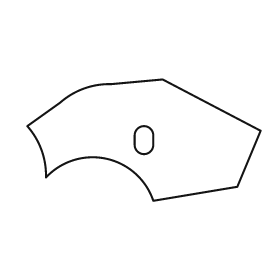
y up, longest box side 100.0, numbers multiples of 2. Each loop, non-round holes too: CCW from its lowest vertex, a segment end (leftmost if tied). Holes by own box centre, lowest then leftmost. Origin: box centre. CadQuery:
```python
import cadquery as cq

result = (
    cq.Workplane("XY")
    .moveTo(4.0, -26.0)
    .lineTo(40.0, -20.0)
    .lineTo(50.0, 4.0)
    .lineTo(8.0, 26.0)
    .lineTo(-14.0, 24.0)
    .threePointArc((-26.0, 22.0), (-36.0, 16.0))
    .lineTo(-50.0, 6.0)
    .threePointArc((-44.0, -4.0), (-42.0, -16.0))
    .threePointArc((-16.0, -8.0), (4.0, -26.0))
    .close()
    .moveTo(-4.0, -2.0)
    .threePointArc((0.0, -6.0), (4.0, -2.0))
    .lineTo(4.0, 2.0)
    .threePointArc((0.0, 6.0), (-4.0, 2.0))
    .close()
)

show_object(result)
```